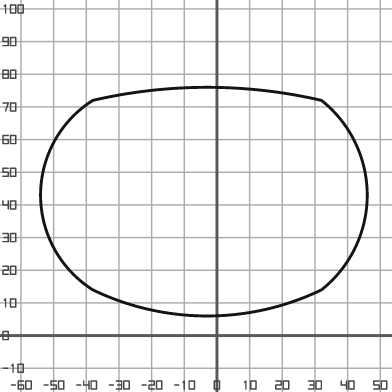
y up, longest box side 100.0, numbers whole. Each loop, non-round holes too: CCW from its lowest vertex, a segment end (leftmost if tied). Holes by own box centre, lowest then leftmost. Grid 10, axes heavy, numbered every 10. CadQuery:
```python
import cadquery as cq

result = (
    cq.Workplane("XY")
    .moveTo(-38.0, 14.0)
    .threePointArc((-3.0, 6.0), (32.0, 14.0))
    .threePointArc((46.0, 43.0), (32.0, 72.0))
    .threePointArc((-3.0, 76.0), (-38.0, 72.0))
    .threePointArc((-54.0, 43.0), (-38.0, 14.0))
    .close()
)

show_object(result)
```